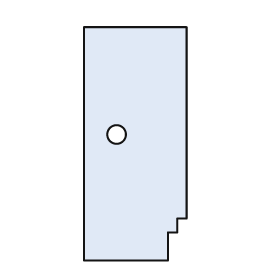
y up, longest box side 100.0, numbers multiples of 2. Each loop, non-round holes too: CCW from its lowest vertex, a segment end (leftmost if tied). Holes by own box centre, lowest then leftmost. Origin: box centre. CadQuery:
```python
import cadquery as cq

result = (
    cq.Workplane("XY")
    .moveTo(-22.0, -50.0)
    .lineTo(14.0, -50.0)
    .lineTo(14.0, -38.0)
    .lineTo(18.0, -38.0)
    .lineTo(18.0, -32.0)
    .lineTo(22.0, -32.0)
    .lineTo(22.0, 50.0)
    .lineTo(-22.0, 50.0)
    .close()
    .moveTo(-8.0, 4.0)
    .circle(4.0)
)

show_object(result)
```